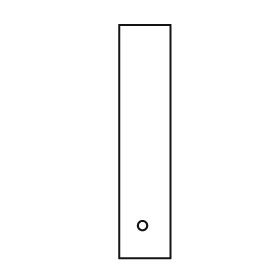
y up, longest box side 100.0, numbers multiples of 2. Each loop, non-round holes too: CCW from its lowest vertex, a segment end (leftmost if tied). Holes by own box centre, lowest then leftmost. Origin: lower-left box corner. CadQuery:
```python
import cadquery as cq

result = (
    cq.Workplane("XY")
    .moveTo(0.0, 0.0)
    .lineTo(22.0, 0.0)
    .lineTo(22.0, 100.0)
    .lineTo(0.0, 100.0)
    .close()
    .moveTo(10.0, 14.0)
    .circle(2.0)
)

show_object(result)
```